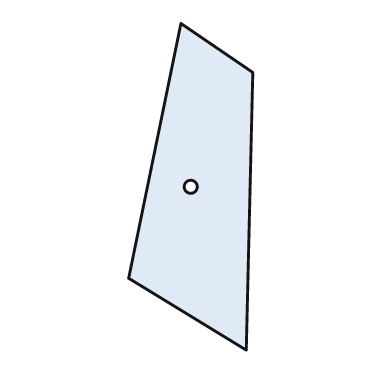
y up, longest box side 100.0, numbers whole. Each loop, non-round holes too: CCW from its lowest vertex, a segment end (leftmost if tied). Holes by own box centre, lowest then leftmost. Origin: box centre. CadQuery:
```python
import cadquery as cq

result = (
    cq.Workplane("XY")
    .moveTo(17.0, -50.0)
    .lineTo(19.0, 35.0)
    .lineTo(-3.0, 50.0)
    .lineTo(-19.0, -28.0)
    .close()
    .moveTo(0.0, 0.0)
    .circle(2.0)
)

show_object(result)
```